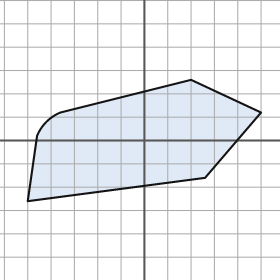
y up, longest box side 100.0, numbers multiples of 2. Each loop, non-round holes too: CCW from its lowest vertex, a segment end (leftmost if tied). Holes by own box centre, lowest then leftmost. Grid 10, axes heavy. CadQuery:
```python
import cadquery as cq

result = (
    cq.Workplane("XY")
    .moveTo(-50.0, -26.0)
    .lineTo(26.0, -16.0)
    .lineTo(50.0, 12.0)
    .lineTo(20.0, 26.0)
    .lineTo(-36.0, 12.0)
    .threePointArc((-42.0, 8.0), (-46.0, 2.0))
    .close()
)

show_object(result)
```